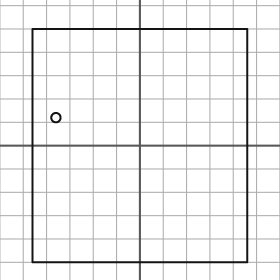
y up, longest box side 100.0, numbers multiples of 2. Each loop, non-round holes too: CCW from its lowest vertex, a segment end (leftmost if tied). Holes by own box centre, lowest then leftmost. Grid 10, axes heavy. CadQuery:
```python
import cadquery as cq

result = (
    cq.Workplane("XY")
    .moveTo(-46.0, -50.0)
    .lineTo(46.0, -50.0)
    .lineTo(46.0, 50.0)
    .lineTo(-46.0, 50.0)
    .close()
    .moveTo(-36.0, 12.0)
    .circle(2.0)
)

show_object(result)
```